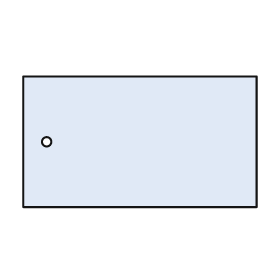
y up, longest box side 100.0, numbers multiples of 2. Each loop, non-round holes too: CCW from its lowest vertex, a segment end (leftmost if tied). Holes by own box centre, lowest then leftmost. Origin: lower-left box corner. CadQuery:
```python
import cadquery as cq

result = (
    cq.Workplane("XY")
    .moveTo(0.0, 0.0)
    .lineTo(100.0, 0.0)
    .lineTo(100.0, 56.0)
    .lineTo(0.0, 56.0)
    .close()
    .moveTo(10.0, 28.0)
    .circle(2.0)
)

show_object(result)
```